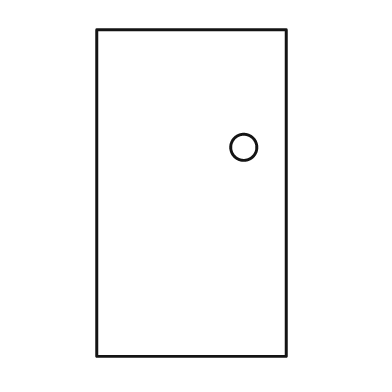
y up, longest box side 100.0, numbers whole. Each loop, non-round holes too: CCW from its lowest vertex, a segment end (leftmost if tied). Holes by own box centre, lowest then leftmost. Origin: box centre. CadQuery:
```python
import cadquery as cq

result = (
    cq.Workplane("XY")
    .moveTo(-29.0, -50.0)
    .lineTo(29.0, -50.0)
    .lineTo(29.0, 50.0)
    .lineTo(-29.0, 50.0)
    .close()
    .moveTo(16.0, 14.0)
    .circle(4.0)
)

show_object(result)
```